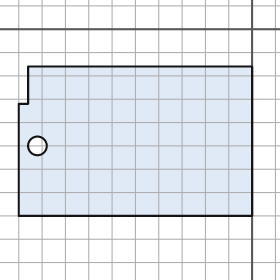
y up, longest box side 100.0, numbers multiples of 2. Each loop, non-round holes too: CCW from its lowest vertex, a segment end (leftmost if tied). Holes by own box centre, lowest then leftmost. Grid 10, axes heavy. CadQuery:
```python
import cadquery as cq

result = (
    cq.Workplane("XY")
    .moveTo(-100.0, -80.0)
    .lineTo(0.0, -80.0)
    .lineTo(0.0, -16.0)
    .lineTo(-96.0, -16.0)
    .lineTo(-96.0, -32.0)
    .lineTo(-100.0, -32.0)
    .close()
    .moveTo(-92.0, -50.0)
    .circle(4.0)
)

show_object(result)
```